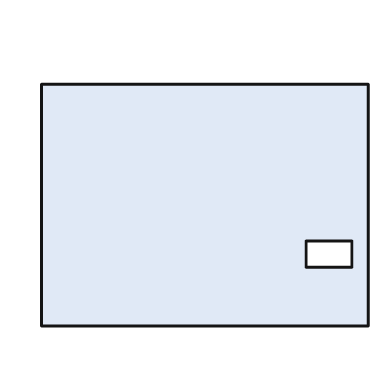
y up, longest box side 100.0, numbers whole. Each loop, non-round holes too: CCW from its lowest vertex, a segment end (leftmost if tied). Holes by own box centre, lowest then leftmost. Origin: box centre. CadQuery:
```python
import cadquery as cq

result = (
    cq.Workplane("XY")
    .moveTo(-50.0, -37.0)
    .lineTo(50.0, -37.0)
    .lineTo(50.0, 37.0)
    .lineTo(-50.0, 37.0)
    .close()
    .moveTo(31.0, -19.0)
    .lineTo(45.0, -19.0)
    .lineTo(45.0, -11.0)
    .lineTo(31.0, -11.0)
    .close()
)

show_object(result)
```